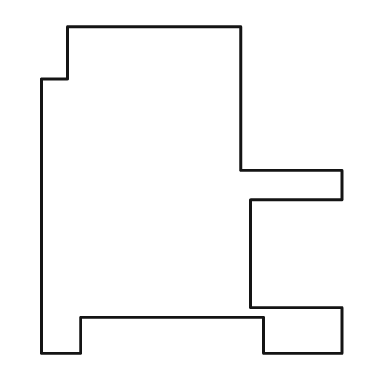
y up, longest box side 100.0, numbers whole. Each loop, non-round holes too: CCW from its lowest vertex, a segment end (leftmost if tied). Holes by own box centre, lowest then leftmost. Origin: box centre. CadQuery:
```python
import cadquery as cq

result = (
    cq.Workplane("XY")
    .moveTo(-46.0, -50.0)
    .lineTo(-34.0, -50.0)
    .lineTo(-34.0, -39.0)
    .lineTo(22.0, -39.0)
    .lineTo(22.0, -50.0)
    .lineTo(46.0, -50.0)
    .lineTo(46.0, -36.0)
    .lineTo(18.0, -36.0)
    .lineTo(18.0, -3.0)
    .lineTo(46.0, -3.0)
    .lineTo(46.0, 6.0)
    .lineTo(15.0, 6.0)
    .lineTo(15.0, 50.0)
    .lineTo(-38.0, 50.0)
    .lineTo(-38.0, 34.0)
    .lineTo(-46.0, 34.0)
    .close()
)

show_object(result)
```